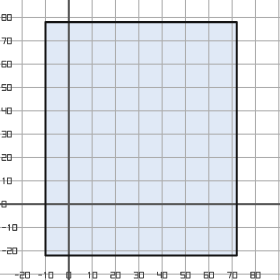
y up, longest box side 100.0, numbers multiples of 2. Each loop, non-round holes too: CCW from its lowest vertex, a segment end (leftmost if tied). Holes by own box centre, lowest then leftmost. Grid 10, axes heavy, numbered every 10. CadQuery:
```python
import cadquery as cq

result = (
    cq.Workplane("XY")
    .moveTo(-10.0, -22.0)
    .lineTo(72.0, -22.0)
    .lineTo(72.0, 78.0)
    .lineTo(-10.0, 78.0)
    .close()
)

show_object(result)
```